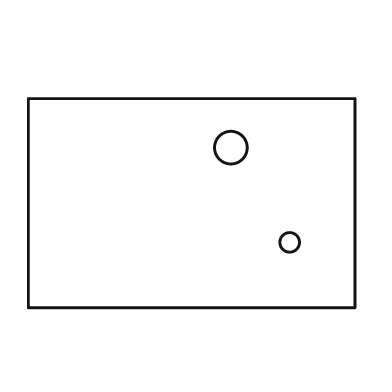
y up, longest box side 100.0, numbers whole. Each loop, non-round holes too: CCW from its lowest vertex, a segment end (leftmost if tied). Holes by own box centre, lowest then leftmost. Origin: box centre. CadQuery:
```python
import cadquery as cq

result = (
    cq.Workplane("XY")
    .moveTo(-50.0, -32.0)
    .lineTo(50.0, -32.0)
    .lineTo(50.0, 32.0)
    .lineTo(-50.0, 32.0)
    .close()
    .moveTo(30.0, -12.0)
    .circle(3.0)
    .moveTo(12.0, 17.0)
    .circle(5.0)
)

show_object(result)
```